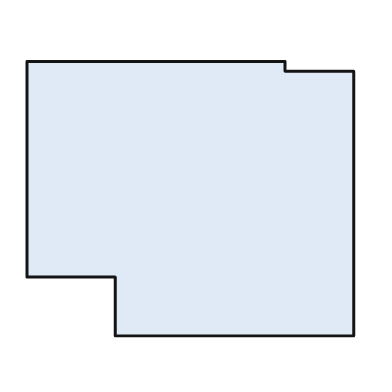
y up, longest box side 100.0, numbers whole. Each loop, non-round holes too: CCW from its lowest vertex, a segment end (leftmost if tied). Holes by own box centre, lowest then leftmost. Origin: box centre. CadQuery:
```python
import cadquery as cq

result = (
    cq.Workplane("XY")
    .moveTo(-23.0, -42.0)
    .lineTo(50.0, -42.0)
    .lineTo(50.0, 39.0)
    .lineTo(29.0, 39.0)
    .lineTo(29.0, 42.0)
    .lineTo(-50.0, 42.0)
    .lineTo(-50.0, -24.0)
    .lineTo(-23.0, -24.0)
    .close()
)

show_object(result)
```